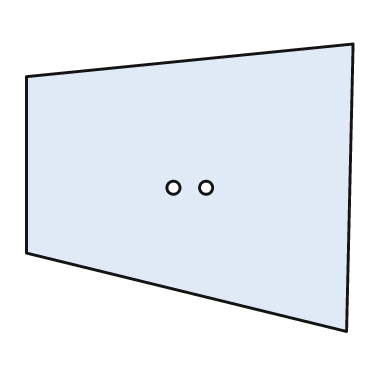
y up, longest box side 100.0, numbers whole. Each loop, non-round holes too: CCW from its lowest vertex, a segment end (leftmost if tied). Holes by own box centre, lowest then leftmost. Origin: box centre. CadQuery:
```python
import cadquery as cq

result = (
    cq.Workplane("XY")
    .moveTo(48.0, -44.0)
    .lineTo(50.0, 44.0)
    .lineTo(-50.0, 34.0)
    .lineTo(-50.0, -20.0)
    .close()
    .moveTo(-5.0, 0.0)
    .circle(2.0)
    .moveTo(5.0, 0.0)
    .circle(2.0)
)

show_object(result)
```